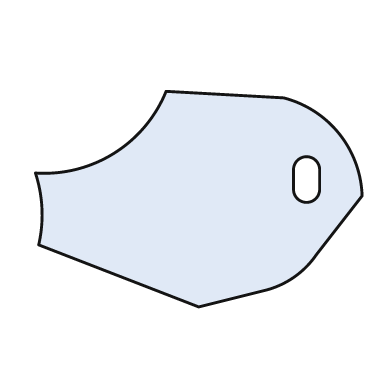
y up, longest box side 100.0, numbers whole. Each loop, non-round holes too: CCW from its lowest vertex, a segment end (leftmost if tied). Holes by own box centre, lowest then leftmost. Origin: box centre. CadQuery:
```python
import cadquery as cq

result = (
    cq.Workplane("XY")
    .moveTo(0.0, -33.0)
    .lineTo(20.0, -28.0)
    .threePointArc((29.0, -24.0), (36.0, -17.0))
    .lineTo(50.0, 1.0)
    .threePointArc((43.0, 20.0), (26.0, 31.0))
    .lineTo(-10.0, 33.0)
    .threePointArc((-26.0, 14.0), (-50.0, 8.0))
    .threePointArc((-48.0, -3.0), (-49.0, -14.0))
    .close()
    .moveTo(29.0, 3.0)
    .threePointArc((33.0, -1.0), (37.0, 3.0))
    .lineTo(37.0, 9.0)
    .threePointArc((33.0, 13.0), (29.0, 9.0))
    .close()
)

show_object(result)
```